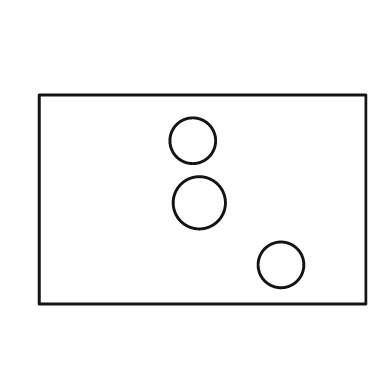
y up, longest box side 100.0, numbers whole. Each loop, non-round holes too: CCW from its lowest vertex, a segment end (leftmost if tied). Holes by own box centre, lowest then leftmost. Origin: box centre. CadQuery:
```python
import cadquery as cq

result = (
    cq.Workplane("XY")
    .moveTo(-50.0, -32.0)
    .lineTo(50.0, -32.0)
    .lineTo(50.0, 32.0)
    .lineTo(-50.0, 32.0)
    .close()
    .moveTo(24.0, -20.0)
    .circle(7.0)
    .moveTo(-1.0, -1.0)
    .circle(8.0)
    .moveTo(-3.0, 18.0)
    .circle(7.0)
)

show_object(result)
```